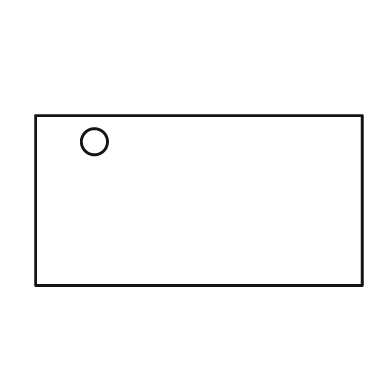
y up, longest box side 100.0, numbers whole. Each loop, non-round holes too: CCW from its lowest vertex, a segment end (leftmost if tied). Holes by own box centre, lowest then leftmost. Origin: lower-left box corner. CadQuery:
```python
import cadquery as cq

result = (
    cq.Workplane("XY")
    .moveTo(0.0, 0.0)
    .lineTo(100.0, 0.0)
    .lineTo(100.0, 52.0)
    .lineTo(0.0, 52.0)
    .close()
    .moveTo(18.0, 44.0)
    .circle(4.0)
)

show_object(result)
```